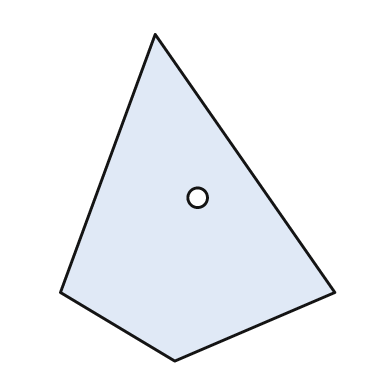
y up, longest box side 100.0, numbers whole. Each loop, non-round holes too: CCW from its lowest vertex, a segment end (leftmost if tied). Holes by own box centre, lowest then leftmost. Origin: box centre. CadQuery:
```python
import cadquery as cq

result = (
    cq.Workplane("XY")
    .moveTo(-7.0, -50.0)
    .lineTo(42.0, -29.0)
    .lineTo(-13.0, 50.0)
    .lineTo(-42.0, -29.0)
    .close()
    .moveTo(0.0, 0.0)
    .circle(3.0)
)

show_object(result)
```